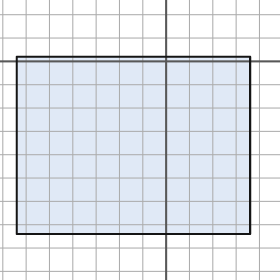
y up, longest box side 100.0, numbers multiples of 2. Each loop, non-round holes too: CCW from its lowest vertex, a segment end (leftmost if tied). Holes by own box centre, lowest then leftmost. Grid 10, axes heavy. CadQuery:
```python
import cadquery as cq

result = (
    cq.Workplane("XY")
    .moveTo(-64.0, -74.0)
    .lineTo(36.0, -74.0)
    .lineTo(36.0, 2.0)
    .lineTo(-64.0, 2.0)
    .close()
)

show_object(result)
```